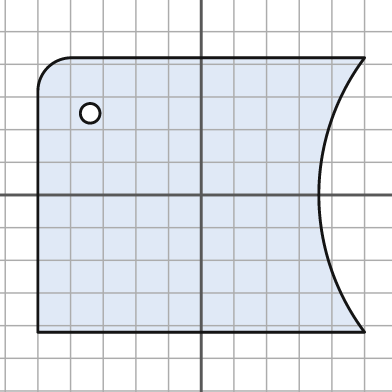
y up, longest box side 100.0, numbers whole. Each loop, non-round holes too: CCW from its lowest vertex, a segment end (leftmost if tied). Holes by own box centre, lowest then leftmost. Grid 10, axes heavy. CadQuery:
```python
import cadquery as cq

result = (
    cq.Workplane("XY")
    .moveTo(-50.0, -42.0)
    .lineTo(50.0, -42.0)
    .threePointArc((36.0, 0.0), (50.0, 42.0))
    .lineTo(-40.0, 42.0)
    .threePointArc((-47.0, 39.0), (-50.0, 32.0))
    .close()
    .moveTo(-34.0, 25.0)
    .circle(3.0)
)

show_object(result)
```